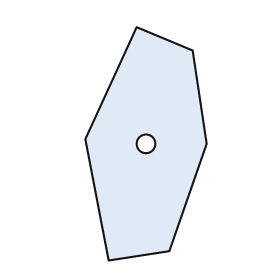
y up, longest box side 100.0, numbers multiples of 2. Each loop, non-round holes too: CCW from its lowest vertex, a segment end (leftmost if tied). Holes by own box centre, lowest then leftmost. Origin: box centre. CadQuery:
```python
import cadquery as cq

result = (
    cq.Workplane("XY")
    .moveTo(-16.0, -50.0)
    .lineTo(10.0, -46.0)
    .lineTo(26.0, 0.0)
    .lineTo(20.0, 40.0)
    .lineTo(-4.0, 50.0)
    .lineTo(-26.0, 2.0)
    .close()
    .moveTo(0.0, 0.0)
    .circle(4.0)
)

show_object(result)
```